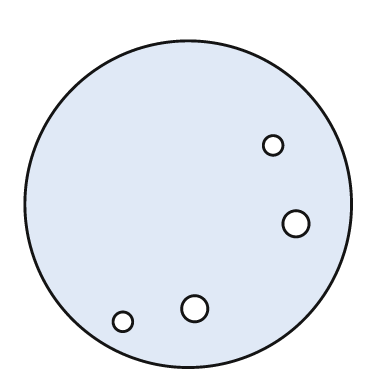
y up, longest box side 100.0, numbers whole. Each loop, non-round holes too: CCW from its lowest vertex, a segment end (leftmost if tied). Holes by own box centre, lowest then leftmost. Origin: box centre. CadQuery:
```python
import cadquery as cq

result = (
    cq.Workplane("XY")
    .moveTo(0.0, 0.0)
    .circle(50.0)
    .moveTo(-20.0, -36.0)
    .circle(3.0)
    .moveTo(2.0, -32.0)
    .circle(4.0)
    .moveTo(33.0, -6.0)
    .circle(4.0)
    .moveTo(26.0, 18.0)
    .circle(3.0)
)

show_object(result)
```